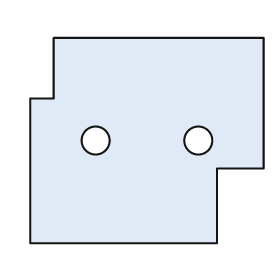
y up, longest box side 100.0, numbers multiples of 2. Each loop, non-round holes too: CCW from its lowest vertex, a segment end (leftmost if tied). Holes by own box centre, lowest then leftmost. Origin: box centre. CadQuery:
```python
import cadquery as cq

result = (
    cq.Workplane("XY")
    .moveTo(-50.0, -44.0)
    .lineTo(30.0, -44.0)
    .lineTo(30.0, -12.0)
    .lineTo(50.0, -12.0)
    .lineTo(50.0, 44.0)
    .lineTo(-40.0, 44.0)
    .lineTo(-40.0, 18.0)
    .lineTo(-50.0, 18.0)
    .close()
    .moveTo(-22.0, 0.0)
    .circle(6.0)
    .moveTo(22.0, 0.0)
    .circle(6.0)
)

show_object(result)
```